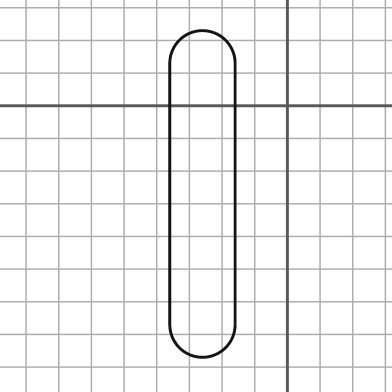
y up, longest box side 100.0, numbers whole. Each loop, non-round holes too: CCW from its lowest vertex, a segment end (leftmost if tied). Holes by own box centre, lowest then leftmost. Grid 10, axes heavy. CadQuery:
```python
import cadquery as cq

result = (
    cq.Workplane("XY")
    .moveTo(-36.0, -67.0)
    .threePointArc((-26.0, -77.0), (-16.0, -67.0))
    .lineTo(-16.0, 13.0)
    .threePointArc((-26.0, 23.0), (-36.0, 13.0))
    .close()
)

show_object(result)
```